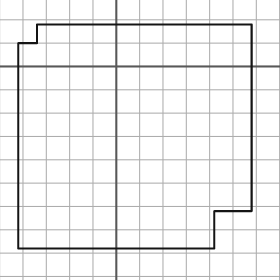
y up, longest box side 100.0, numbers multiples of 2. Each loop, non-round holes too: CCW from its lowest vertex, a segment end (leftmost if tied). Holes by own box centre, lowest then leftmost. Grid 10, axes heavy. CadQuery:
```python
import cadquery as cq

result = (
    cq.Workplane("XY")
    .moveTo(-42.0, -78.0)
    .lineTo(42.0, -78.0)
    .lineTo(42.0, -62.0)
    .lineTo(58.0, -62.0)
    .lineTo(58.0, 18.0)
    .lineTo(-34.0, 18.0)
    .lineTo(-34.0, 10.0)
    .lineTo(-42.0, 10.0)
    .close()
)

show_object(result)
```